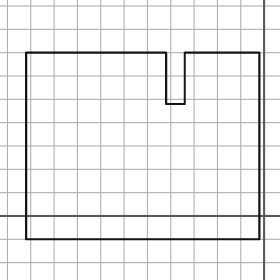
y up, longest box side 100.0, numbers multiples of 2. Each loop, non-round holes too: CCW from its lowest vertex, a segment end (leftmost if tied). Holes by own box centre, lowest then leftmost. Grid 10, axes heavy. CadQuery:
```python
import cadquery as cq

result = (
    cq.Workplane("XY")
    .moveTo(-102.0, -10.0)
    .lineTo(-2.0, -10.0)
    .lineTo(-2.0, 70.0)
    .lineTo(-34.0, 70.0)
    .lineTo(-34.0, 48.0)
    .lineTo(-42.0, 48.0)
    .lineTo(-42.0, 70.0)
    .lineTo(-102.0, 70.0)
    .close()
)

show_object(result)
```